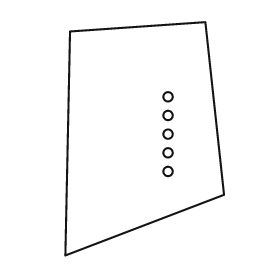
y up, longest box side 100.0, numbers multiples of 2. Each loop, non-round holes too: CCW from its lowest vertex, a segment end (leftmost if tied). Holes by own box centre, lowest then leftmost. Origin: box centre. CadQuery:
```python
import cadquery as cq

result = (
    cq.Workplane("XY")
    .moveTo(-34.0, -50.0)
    .lineTo(34.0, -24.0)
    .lineTo(26.0, 50.0)
    .lineTo(-32.0, 46.0)
    .close()
    .moveTo(10.0, -14.0)
    .circle(2.0)
    .moveTo(10.0, -6.0)
    .circle(2.0)
    .moveTo(10.0, 2.0)
    .circle(2.0)
    .moveTo(10.0, 10.0)
    .circle(2.0)
    .moveTo(10.0, 18.0)
    .circle(2.0)
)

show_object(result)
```